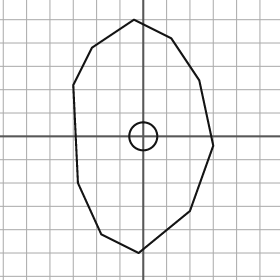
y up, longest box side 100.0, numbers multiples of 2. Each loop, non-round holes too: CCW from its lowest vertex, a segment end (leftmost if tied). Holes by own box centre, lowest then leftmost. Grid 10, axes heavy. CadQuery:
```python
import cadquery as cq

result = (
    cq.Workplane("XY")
    .moveTo(-2.0, -50.0)
    .lineTo(20.0, -32.0)
    .lineTo(30.0, -4.0)
    .lineTo(24.0, 24.0)
    .lineTo(12.0, 42.0)
    .lineTo(-4.0, 50.0)
    .lineTo(-22.0, 38.0)
    .lineTo(-30.0, 22.0)
    .lineTo(-28.0, -20.0)
    .lineTo(-18.0, -42.0)
    .close()
    .moveTo(0.0, 0.0)
    .circle(6.0)
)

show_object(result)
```